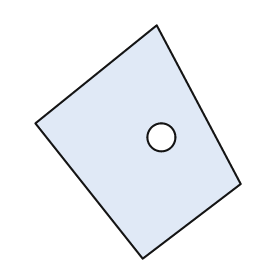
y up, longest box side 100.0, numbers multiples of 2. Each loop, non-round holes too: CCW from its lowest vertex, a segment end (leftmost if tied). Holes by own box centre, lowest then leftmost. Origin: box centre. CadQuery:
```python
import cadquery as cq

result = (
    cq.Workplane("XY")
    .moveTo(2.0, -50.0)
    .lineTo(44.0, -18.0)
    .lineTo(8.0, 50.0)
    .lineTo(-44.0, 8.0)
    .close()
    .moveTo(10.0, 2.0)
    .circle(6.0)
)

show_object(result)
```